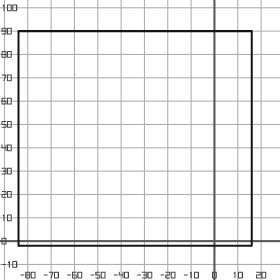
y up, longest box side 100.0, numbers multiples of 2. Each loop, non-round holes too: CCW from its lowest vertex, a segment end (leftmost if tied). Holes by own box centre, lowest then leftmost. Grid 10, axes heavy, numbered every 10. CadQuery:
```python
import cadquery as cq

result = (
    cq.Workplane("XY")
    .moveTo(-84.0, -2.0)
    .lineTo(16.0, -2.0)
    .lineTo(16.0, 90.0)
    .lineTo(-84.0, 90.0)
    .close()
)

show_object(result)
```